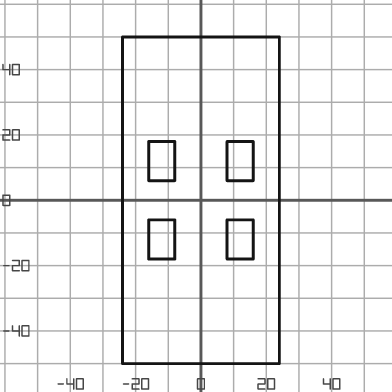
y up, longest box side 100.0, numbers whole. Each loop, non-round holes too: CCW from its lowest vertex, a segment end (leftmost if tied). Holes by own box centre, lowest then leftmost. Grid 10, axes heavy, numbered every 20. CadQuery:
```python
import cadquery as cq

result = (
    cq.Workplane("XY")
    .moveTo(-24.0, -50.0)
    .lineTo(24.0, -50.0)
    .lineTo(24.0, 50.0)
    .lineTo(-24.0, 50.0)
    .close()
    .moveTo(-16.0, -18.0)
    .lineTo(-8.0, -18.0)
    .lineTo(-8.0, -6.0)
    .lineTo(-16.0, -6.0)
    .close()
    .moveTo(8.0, -18.0)
    .lineTo(16.0, -18.0)
    .lineTo(16.0, -6.0)
    .lineTo(8.0, -6.0)
    .close()
    .moveTo(-16.0, 6.0)
    .lineTo(-8.0, 6.0)
    .lineTo(-8.0, 18.0)
    .lineTo(-16.0, 18.0)
    .close()
    .moveTo(8.0, 6.0)
    .lineTo(16.0, 6.0)
    .lineTo(16.0, 18.0)
    .lineTo(8.0, 18.0)
    .close()
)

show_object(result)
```